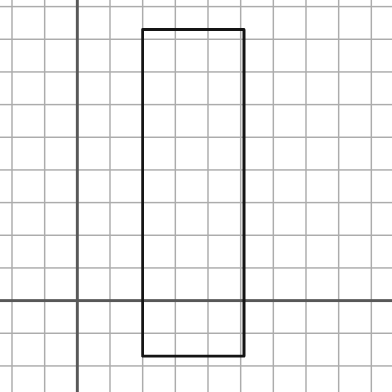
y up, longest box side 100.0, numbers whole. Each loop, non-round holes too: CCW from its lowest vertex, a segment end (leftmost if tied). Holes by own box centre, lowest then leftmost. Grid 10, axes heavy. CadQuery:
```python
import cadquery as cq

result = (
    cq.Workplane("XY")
    .moveTo(20.0, -17.0)
    .lineTo(51.0, -17.0)
    .lineTo(51.0, 83.0)
    .lineTo(20.0, 83.0)
    .close()
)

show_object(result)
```